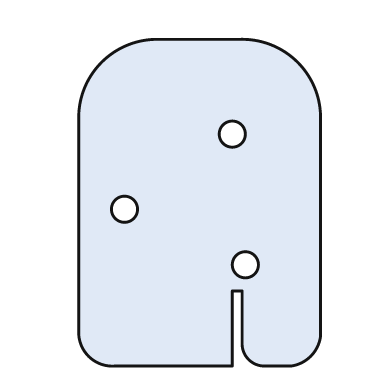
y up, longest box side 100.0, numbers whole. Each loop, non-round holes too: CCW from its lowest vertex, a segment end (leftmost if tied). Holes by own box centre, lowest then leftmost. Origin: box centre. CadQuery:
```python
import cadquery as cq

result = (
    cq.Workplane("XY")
    .moveTo(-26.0, -50.0)
    .lineTo(10.0, -50.0)
    .lineTo(10.0, -27.0)
    .lineTo(13.0, -27.0)
    .lineTo(13.0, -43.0)
    .threePointArc((15.0, -48.0), (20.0, -50.0))
    .lineTo(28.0, -50.0)
    .threePointArc((34.0, -47.0), (37.0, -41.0))
    .lineTo(37.0, 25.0)
    .threePointArc((30.0, 43.0), (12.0, 50.0))
    .lineTo(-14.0, 50.0)
    .threePointArc((-30.0, 43.0), (-37.0, 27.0))
    .lineTo(-37.0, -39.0)
    .threePointArc((-34.0, -47.0), (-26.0, -50.0))
    .close()
    .moveTo(14.0, -19.0)
    .circle(4.0)
    .moveTo(-23.0, -2.0)
    .circle(4.0)
    .moveTo(10.0, 21.0)
    .circle(4.0)
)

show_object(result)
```